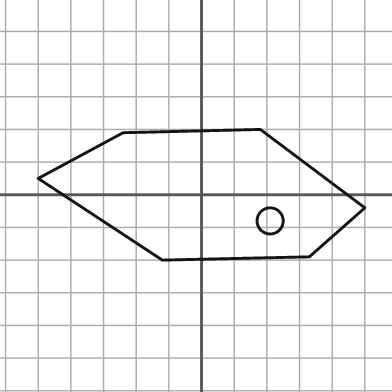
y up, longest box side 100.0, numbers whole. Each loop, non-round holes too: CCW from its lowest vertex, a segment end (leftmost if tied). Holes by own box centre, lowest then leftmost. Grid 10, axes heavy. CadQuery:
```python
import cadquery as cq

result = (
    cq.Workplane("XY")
    .moveTo(-12.0, -20.0)
    .lineTo(33.0, -19.0)
    .lineTo(50.0, -4.0)
    .lineTo(18.0, 20.0)
    .lineTo(-24.0, 19.0)
    .lineTo(-50.0, 5.0)
    .close()
    .moveTo(21.0, -8.0)
    .circle(4.0)
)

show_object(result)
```